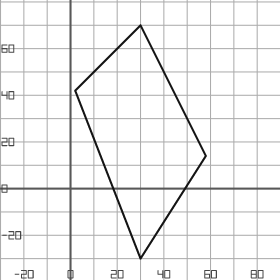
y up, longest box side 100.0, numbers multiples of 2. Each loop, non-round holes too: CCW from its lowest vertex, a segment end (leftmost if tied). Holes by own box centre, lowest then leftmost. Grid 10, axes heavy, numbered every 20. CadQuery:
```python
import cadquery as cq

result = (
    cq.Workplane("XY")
    .moveTo(30.0, -30.0)
    .lineTo(58.0, 14.0)
    .lineTo(30.0, 70.0)
    .lineTo(2.0, 42.0)
    .close()
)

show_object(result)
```